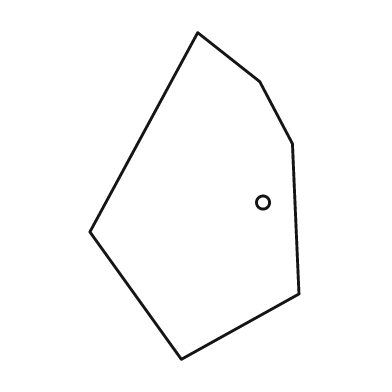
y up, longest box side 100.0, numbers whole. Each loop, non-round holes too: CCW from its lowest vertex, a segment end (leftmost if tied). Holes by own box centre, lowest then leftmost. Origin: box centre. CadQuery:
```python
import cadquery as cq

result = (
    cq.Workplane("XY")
    .moveTo(-4.0, -50.0)
    .lineTo(32.0, -30.0)
    .lineTo(30.0, 16.0)
    .lineTo(20.0, 35.0)
    .lineTo(1.0, 50.0)
    .lineTo(-32.0, -11.0)
    .close()
    .moveTo(21.0, -2.0)
    .circle(2.0)
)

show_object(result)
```